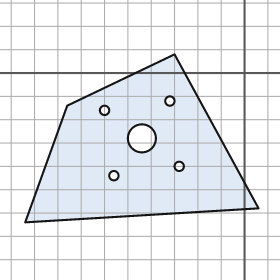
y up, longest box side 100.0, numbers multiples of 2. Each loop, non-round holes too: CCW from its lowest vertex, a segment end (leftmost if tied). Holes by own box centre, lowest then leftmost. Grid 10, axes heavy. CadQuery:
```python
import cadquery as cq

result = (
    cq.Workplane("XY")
    .moveTo(-94.0, -64.0)
    .lineTo(6.0, -58.0)
    .lineTo(-30.0, 8.0)
    .lineTo(-76.0, -14.0)
    .close()
    .moveTo(-56.0, -44.0)
    .circle(2.0)
    .moveTo(-28.0, -40.0)
    .circle(2.0)
    .moveTo(-44.0, -28.0)
    .circle(6.0)
    .moveTo(-60.0, -16.0)
    .circle(2.0)
    .moveTo(-32.0, -12.0)
    .circle(2.0)
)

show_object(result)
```